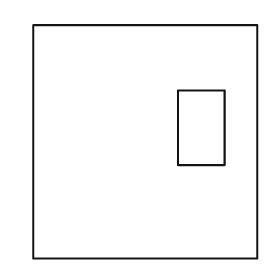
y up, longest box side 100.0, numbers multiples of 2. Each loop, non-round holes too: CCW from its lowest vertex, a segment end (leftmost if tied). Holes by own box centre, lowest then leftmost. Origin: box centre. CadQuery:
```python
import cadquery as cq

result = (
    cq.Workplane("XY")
    .moveTo(-48.0, -50.0)
    .lineTo(48.0, -50.0)
    .lineTo(48.0, 50.0)
    .lineTo(-48.0, 50.0)
    .close()
    .moveTo(14.0, -10.0)
    .lineTo(34.0, -10.0)
    .lineTo(34.0, 22.0)
    .lineTo(14.0, 22.0)
    .close()
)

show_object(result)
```